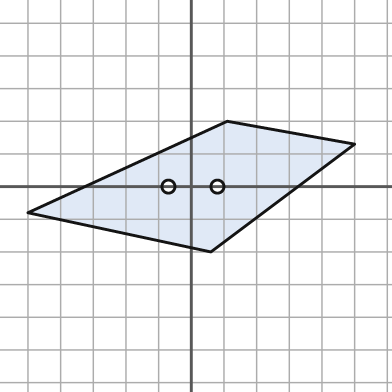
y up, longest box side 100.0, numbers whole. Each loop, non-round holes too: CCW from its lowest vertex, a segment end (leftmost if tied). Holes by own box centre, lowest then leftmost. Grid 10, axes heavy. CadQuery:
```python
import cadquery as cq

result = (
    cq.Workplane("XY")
    .moveTo(6.0, -20.0)
    .lineTo(50.0, 13.0)
    .lineTo(11.0, 20.0)
    .lineTo(-50.0, -8.0)
    .close()
    .moveTo(-7.0, 0.0)
    .circle(2.0)
    .moveTo(8.0, 0.0)
    .circle(2.0)
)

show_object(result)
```